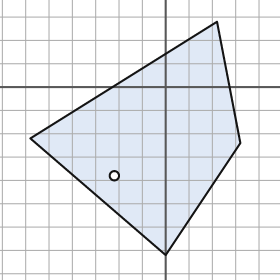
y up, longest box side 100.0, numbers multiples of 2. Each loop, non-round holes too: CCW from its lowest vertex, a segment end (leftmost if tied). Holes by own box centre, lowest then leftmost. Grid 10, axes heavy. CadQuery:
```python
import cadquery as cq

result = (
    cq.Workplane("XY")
    .moveTo(0.0, -72.0)
    .lineTo(32.0, -24.0)
    .lineTo(22.0, 28.0)
    .lineTo(-58.0, -22.0)
    .close()
    .moveTo(-22.0, -38.0)
    .circle(2.0)
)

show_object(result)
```